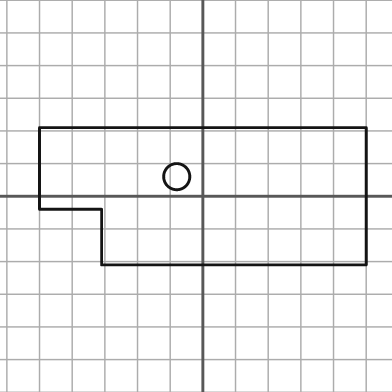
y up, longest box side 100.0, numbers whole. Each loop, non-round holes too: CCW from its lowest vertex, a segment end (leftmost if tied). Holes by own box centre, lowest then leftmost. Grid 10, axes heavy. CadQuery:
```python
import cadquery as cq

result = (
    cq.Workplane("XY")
    .moveTo(-31.0, -21.0)
    .lineTo(50.0, -21.0)
    .lineTo(50.0, 21.0)
    .lineTo(-50.0, 21.0)
    .lineTo(-50.0, -4.0)
    .lineTo(-31.0, -4.0)
    .close()
    .moveTo(-8.0, 6.0)
    .circle(4.0)
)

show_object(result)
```